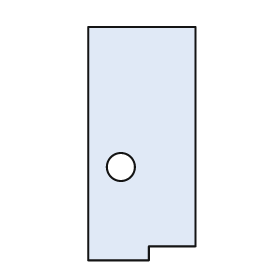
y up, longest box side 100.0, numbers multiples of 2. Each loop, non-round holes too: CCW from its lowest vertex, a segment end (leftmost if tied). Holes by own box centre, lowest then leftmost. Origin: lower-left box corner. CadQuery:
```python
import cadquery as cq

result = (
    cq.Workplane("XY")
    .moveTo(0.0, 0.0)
    .lineTo(26.0, 0.0)
    .lineTo(26.0, 6.0)
    .lineTo(46.0, 6.0)
    .lineTo(46.0, 100.0)
    .lineTo(0.0, 100.0)
    .close()
    .moveTo(14.0, 40.0)
    .circle(6.0)
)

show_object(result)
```